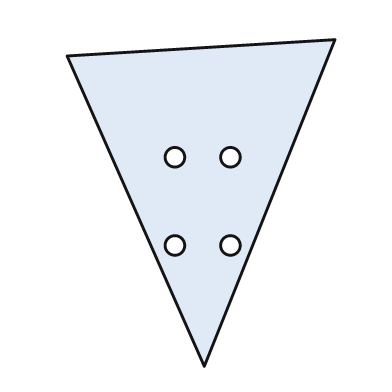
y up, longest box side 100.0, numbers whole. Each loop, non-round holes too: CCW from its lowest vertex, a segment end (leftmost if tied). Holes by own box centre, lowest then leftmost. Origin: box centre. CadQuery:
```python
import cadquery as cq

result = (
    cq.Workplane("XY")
    .moveTo(1.0, -50.0)
    .lineTo(41.0, 50.0)
    .lineTo(-41.0, 45.0)
    .close()
    .moveTo(-8.0, -13.0)
    .circle(3.0)
    .moveTo(9.0, -13.0)
    .circle(3.0)
    .moveTo(-8.0, 14.0)
    .circle(3.0)
    .moveTo(9.0, 14.0)
    .circle(3.0)
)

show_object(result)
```